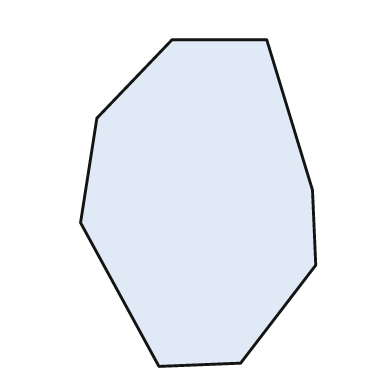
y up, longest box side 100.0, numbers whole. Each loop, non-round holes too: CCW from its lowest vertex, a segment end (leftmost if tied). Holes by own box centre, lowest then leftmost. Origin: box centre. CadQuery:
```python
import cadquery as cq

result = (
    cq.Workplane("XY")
    .moveTo(-12.0, -50.0)
    .lineTo(13.0, -49.0)
    .lineTo(36.0, -19.0)
    .lineTo(35.0, 4.0)
    .lineTo(21.0, 50.0)
    .lineTo(-8.0, 50.0)
    .lineTo(-31.0, 26.0)
    .lineTo(-36.0, -6.0)
    .close()
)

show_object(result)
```